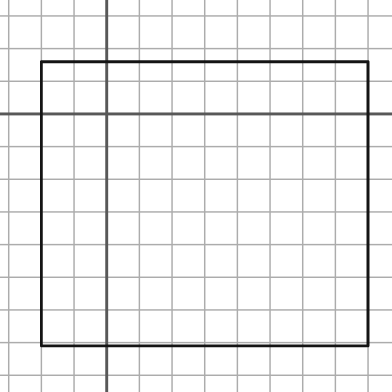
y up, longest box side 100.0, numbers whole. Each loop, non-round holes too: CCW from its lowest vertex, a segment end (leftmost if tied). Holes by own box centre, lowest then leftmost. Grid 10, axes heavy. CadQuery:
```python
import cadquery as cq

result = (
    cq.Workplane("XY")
    .moveTo(-20.0, -71.0)
    .lineTo(80.0, -71.0)
    .lineTo(80.0, 16.0)
    .lineTo(-20.0, 16.0)
    .close()
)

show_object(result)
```